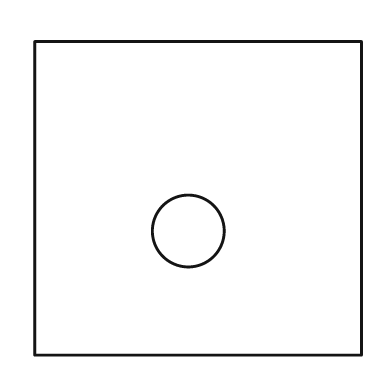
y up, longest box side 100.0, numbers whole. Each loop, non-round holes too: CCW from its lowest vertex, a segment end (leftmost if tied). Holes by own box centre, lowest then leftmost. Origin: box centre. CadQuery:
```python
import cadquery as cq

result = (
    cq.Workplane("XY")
    .moveTo(-50.0, -48.0)
    .lineTo(50.0, -48.0)
    .lineTo(50.0, 48.0)
    .lineTo(-50.0, 48.0)
    .close()
    .moveTo(-3.0, -10.0)
    .circle(11.0)
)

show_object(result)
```